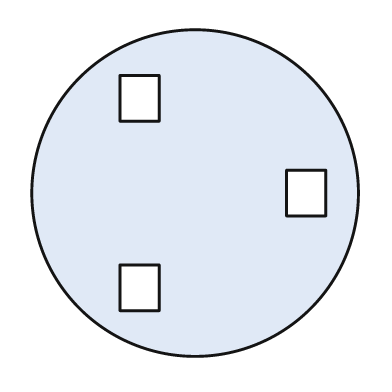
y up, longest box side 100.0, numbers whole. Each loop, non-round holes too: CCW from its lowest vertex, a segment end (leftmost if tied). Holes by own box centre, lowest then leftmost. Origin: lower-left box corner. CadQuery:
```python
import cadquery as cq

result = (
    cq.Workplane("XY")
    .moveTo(50.0, 50.0)
    .circle(50.0)
    .moveTo(27.0, 14.0)
    .lineTo(39.0, 14.0)
    .lineTo(39.0, 28.0)
    .lineTo(27.0, 28.0)
    .close()
    .moveTo(78.0, 43.0)
    .lineTo(90.0, 43.0)
    .lineTo(90.0, 57.0)
    .lineTo(78.0, 57.0)
    .close()
    .moveTo(27.0, 72.0)
    .lineTo(39.0, 72.0)
    .lineTo(39.0, 86.0)
    .lineTo(27.0, 86.0)
    .close()
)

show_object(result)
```